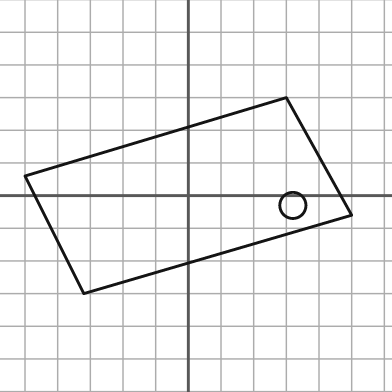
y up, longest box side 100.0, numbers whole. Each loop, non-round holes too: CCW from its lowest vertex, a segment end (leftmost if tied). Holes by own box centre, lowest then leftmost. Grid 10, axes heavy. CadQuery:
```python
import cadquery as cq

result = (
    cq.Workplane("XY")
    .moveTo(-32.0, -30.0)
    .lineTo(50.0, -6.0)
    .lineTo(30.0, 30.0)
    .lineTo(-50.0, 6.0)
    .close()
    .moveTo(32.0, -3.0)
    .circle(4.0)
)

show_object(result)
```